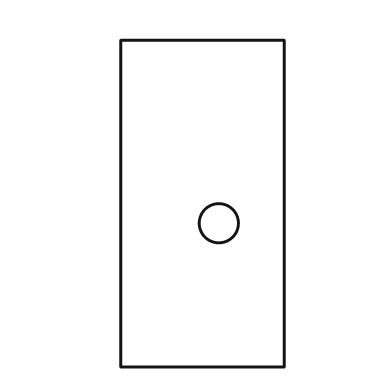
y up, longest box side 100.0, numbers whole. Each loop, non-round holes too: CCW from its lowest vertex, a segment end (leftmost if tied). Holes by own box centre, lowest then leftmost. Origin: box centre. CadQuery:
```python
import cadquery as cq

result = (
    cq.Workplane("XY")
    .moveTo(-25.0, -50.0)
    .lineTo(25.0, -50.0)
    .lineTo(25.0, 50.0)
    .lineTo(-25.0, 50.0)
    .close()
    .moveTo(5.0, -6.0)
    .circle(6.0)
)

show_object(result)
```